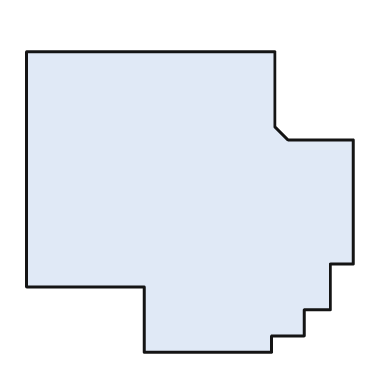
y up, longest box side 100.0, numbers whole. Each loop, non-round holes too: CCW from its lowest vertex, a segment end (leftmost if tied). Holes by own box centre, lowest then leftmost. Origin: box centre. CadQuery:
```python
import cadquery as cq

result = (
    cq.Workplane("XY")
    .moveTo(-14.0, -46.0)
    .lineTo(25.0, -46.0)
    .lineTo(25.0, -41.0)
    .lineTo(35.0, -41.0)
    .lineTo(35.0, -33.0)
    .lineTo(43.0, -33.0)
    .lineTo(43.0, -19.0)
    .lineTo(50.0, -19.0)
    .lineTo(50.0, 19.0)
    .lineTo(30.0, 19.0)
    .lineTo(26.0, 23.0)
    .lineTo(26.0, 46.0)
    .lineTo(-50.0, 46.0)
    .lineTo(-50.0, -26.0)
    .lineTo(-14.0, -26.0)
    .close()
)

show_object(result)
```